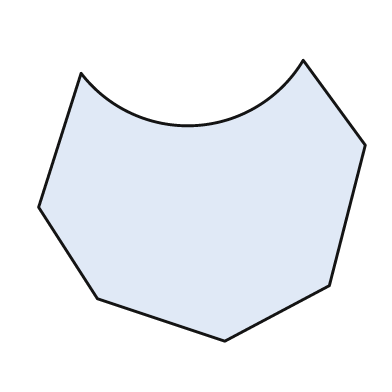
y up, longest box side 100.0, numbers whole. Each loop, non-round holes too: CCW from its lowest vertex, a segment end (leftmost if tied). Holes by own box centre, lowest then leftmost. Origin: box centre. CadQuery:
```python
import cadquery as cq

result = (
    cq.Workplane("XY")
    .moveTo(7.0, -43.0)
    .lineTo(39.0, -26.0)
    .lineTo(50.0, 17.0)
    .lineTo(31.0, 43.0)
    .threePointArc((-2.0, 23.0), (-37.0, 39.0))
    .lineTo(-50.0, -2.0)
    .lineTo(-32.0, -30.0)
    .close()
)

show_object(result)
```